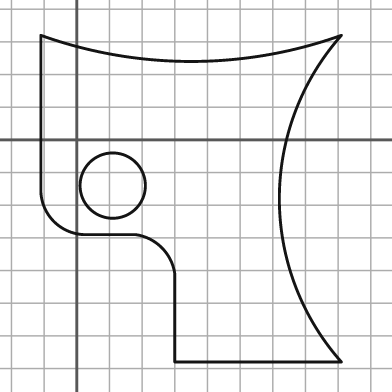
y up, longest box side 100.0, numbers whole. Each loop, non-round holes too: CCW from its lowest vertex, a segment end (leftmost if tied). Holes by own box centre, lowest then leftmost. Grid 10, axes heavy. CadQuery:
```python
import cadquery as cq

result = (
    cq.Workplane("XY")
    .moveTo(30.0, -68.0)
    .lineTo(81.0, -68.0)
    .threePointArc((62.0, -18.0), (81.0, 32.0))
    .threePointArc((35.0, 24.0), (-11.0, 32.0))
    .lineTo(-11.0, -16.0)
    .threePointArc((-7.0, -25.0), (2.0, -29.0))
    .lineTo(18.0, -29.0)
    .threePointArc((26.0, -33.0), (30.0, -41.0))
    .close()
    .moveTo(11.0, -14.0)
    .circle(10.0)
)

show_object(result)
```